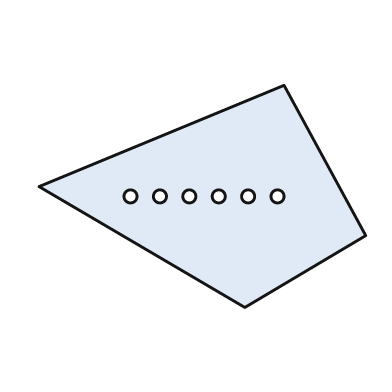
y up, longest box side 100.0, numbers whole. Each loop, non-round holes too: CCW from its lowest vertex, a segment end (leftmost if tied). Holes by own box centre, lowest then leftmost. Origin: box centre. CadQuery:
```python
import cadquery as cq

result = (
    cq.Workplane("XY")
    .moveTo(13.0, -34.0)
    .lineTo(50.0, -12.0)
    .lineTo(25.0, 34.0)
    .lineTo(-50.0, 3.0)
    .close()
    .moveTo(-22.0, 0.0)
    .circle(2.0)
    .moveTo(-13.0, 0.0)
    .circle(2.0)
    .moveTo(-4.0, 0.0)
    .circle(2.0)
    .moveTo(5.0, 0.0)
    .circle(2.0)
    .moveTo(14.0, 0.0)
    .circle(2.0)
    .moveTo(23.0, 0.0)
    .circle(2.0)
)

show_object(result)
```